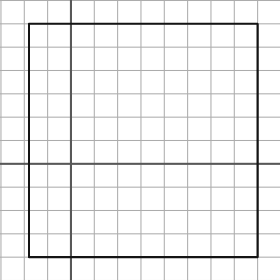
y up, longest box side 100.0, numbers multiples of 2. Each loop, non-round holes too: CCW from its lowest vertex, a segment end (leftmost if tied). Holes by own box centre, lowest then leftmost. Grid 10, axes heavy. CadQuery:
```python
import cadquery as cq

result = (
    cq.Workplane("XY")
    .moveTo(-18.0, -40.0)
    .lineTo(80.0, -40.0)
    .lineTo(80.0, 60.0)
    .lineTo(-18.0, 60.0)
    .close()
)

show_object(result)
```